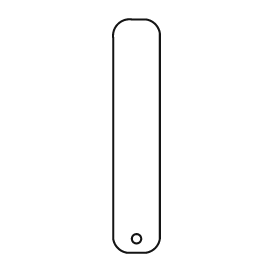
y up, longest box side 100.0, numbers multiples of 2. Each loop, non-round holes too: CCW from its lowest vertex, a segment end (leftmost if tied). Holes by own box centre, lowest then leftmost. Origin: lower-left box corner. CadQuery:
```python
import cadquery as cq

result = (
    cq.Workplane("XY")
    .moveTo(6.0, 0.0)
    .lineTo(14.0, 0.0)
    .threePointArc((18.0, 2.0), (20.0, 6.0))
    .lineTo(20.0, 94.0)
    .threePointArc((18.0, 98.0), (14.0, 100.0))
    .lineTo(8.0, 100.0)
    .threePointArc((2.0, 98.0), (0.0, 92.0))
    .lineTo(0.0, 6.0)
    .threePointArc((2.0, 2.0), (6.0, 0.0))
    .close()
    .moveTo(10.0, 6.0)
    .circle(2.0)
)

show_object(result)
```